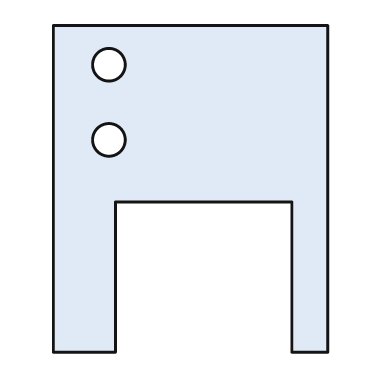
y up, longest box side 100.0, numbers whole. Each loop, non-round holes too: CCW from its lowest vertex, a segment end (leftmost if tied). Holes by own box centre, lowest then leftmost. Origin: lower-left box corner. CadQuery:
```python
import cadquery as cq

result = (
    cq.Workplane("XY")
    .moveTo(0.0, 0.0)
    .lineTo(19.0, 0.0)
    .lineTo(19.0, 46.0)
    .lineTo(73.0, 46.0)
    .lineTo(73.0, 0.0)
    .lineTo(84.0, 0.0)
    .lineTo(84.0, 100.0)
    .lineTo(0.0, 100.0)
    .close()
    .moveTo(17.0, 65.0)
    .circle(5.0)
    .moveTo(17.0, 88.0)
    .circle(5.0)
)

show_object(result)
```